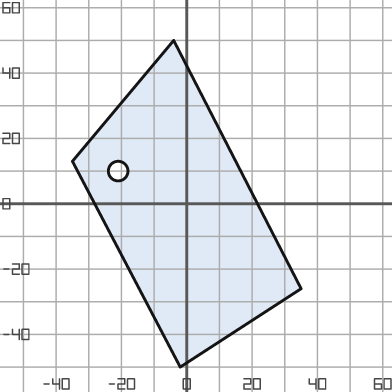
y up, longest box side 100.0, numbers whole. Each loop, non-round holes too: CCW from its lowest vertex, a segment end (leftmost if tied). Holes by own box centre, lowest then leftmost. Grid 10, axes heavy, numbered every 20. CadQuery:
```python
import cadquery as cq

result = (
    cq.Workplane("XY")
    .moveTo(-2.0, -50.0)
    .lineTo(35.0, -26.0)
    .lineTo(-4.0, 50.0)
    .lineTo(-35.0, 13.0)
    .close()
    .moveTo(-21.0, 10.0)
    .circle(3.0)
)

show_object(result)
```